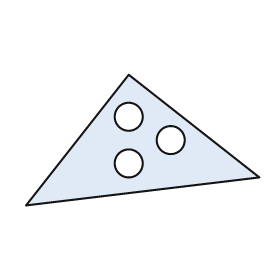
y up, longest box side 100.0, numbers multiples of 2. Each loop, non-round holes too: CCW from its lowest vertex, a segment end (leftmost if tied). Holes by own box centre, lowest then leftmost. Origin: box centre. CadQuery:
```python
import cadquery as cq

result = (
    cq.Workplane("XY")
    .moveTo(-50.0, -28.0)
    .lineTo(50.0, -16.0)
    .lineTo(-6.0, 28.0)
    .close()
    .moveTo(-6.0, -10.0)
    .circle(6.0)
    .moveTo(12.0, 0.0)
    .circle(6.0)
    .moveTo(-6.0, 10.0)
    .circle(6.0)
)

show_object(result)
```